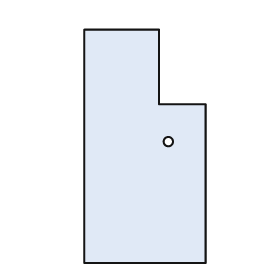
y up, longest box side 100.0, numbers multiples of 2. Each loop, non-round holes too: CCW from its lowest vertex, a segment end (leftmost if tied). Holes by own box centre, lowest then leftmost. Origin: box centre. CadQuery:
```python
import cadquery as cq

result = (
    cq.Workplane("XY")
    .moveTo(-26.0, -50.0)
    .lineTo(26.0, -50.0)
    .lineTo(26.0, 18.0)
    .lineTo(6.0, 18.0)
    .lineTo(6.0, 50.0)
    .lineTo(-26.0, 50.0)
    .close()
    .moveTo(10.0, 2.0)
    .circle(2.0)
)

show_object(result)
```